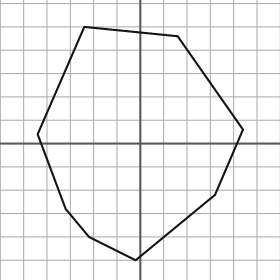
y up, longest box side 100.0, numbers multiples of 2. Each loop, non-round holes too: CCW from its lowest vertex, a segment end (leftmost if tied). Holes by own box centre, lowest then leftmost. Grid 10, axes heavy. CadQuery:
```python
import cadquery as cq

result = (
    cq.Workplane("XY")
    .moveTo(-2.0, -50.0)
    .lineTo(32.0, -22.0)
    .lineTo(44.0, 6.0)
    .lineTo(16.0, 46.0)
    .lineTo(-24.0, 50.0)
    .lineTo(-44.0, 4.0)
    .lineTo(-32.0, -28.0)
    .lineTo(-22.0, -40.0)
    .close()
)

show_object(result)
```